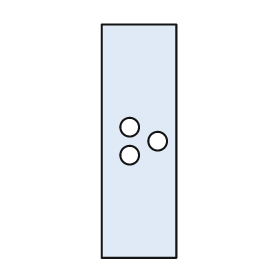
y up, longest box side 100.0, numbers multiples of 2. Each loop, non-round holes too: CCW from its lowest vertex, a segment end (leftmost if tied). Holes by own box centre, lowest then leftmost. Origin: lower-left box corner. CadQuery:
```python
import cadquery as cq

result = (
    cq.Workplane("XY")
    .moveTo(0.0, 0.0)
    .lineTo(32.0, 0.0)
    .lineTo(32.0, 100.0)
    .lineTo(0.0, 100.0)
    .close()
    .moveTo(12.0, 44.0)
    .circle(4.0)
    .moveTo(24.0, 50.0)
    .circle(4.0)
    .moveTo(12.0, 56.0)
    .circle(4.0)
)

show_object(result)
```